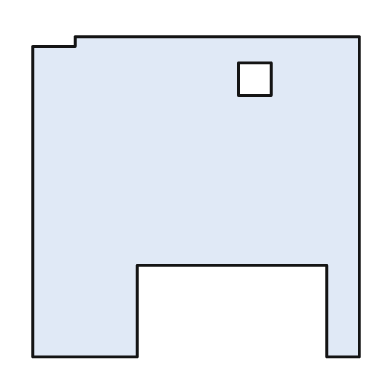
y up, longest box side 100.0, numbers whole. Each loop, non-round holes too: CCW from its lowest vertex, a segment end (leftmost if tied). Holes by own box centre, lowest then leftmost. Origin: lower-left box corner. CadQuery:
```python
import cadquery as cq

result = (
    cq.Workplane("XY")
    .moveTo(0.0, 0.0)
    .lineTo(32.0, 0.0)
    .lineTo(32.0, 28.0)
    .lineTo(90.0, 28.0)
    .lineTo(90.0, 0.0)
    .lineTo(100.0, 0.0)
    .lineTo(100.0, 98.0)
    .lineTo(13.0, 98.0)
    .lineTo(13.0, 95.0)
    .lineTo(0.0, 95.0)
    .close()
    .moveTo(63.0, 80.0)
    .lineTo(73.0, 80.0)
    .lineTo(73.0, 90.0)
    .lineTo(63.0, 90.0)
    .close()
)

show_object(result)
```